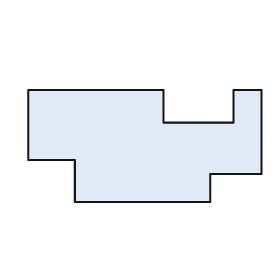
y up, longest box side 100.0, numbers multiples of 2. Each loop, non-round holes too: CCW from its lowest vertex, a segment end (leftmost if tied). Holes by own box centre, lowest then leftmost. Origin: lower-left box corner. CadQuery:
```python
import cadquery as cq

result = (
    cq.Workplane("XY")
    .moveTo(20.0, 0.0)
    .lineTo(78.0, 0.0)
    .lineTo(78.0, 12.0)
    .lineTo(100.0, 12.0)
    .lineTo(100.0, 48.0)
    .lineTo(88.0, 48.0)
    .lineTo(88.0, 34.0)
    .lineTo(58.0, 34.0)
    .lineTo(58.0, 48.0)
    .lineTo(0.0, 48.0)
    .lineTo(0.0, 18.0)
    .lineTo(20.0, 18.0)
    .close()
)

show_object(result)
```